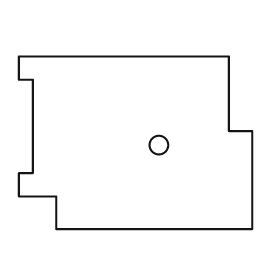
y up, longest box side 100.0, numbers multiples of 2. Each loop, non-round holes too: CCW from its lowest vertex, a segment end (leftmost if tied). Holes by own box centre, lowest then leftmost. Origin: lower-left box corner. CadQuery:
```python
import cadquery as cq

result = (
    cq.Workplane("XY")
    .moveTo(16.0, 0.0)
    .lineTo(100.0, 0.0)
    .lineTo(100.0, 42.0)
    .lineTo(90.0, 42.0)
    .lineTo(90.0, 74.0)
    .lineTo(0.0, 74.0)
    .lineTo(0.0, 64.0)
    .lineTo(6.0, 64.0)
    .lineTo(6.0, 24.0)
    .lineTo(0.0, 24.0)
    .lineTo(0.0, 14.0)
    .lineTo(16.0, 14.0)
    .close()
    .moveTo(60.0, 36.0)
    .circle(4.0)
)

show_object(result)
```